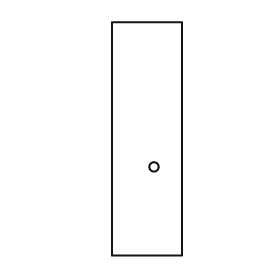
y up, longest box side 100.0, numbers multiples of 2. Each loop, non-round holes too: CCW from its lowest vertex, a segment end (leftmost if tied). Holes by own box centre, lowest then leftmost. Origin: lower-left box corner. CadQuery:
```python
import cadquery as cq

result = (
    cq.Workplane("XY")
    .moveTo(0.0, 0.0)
    .lineTo(30.0, 0.0)
    .lineTo(30.0, 100.0)
    .lineTo(0.0, 100.0)
    .close()
    .moveTo(18.0, 38.0)
    .circle(2.0)
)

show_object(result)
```